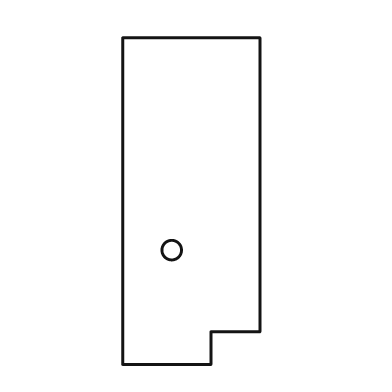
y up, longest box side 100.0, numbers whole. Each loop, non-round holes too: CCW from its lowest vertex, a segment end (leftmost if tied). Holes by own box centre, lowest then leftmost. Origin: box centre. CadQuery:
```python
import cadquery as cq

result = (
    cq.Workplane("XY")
    .moveTo(-21.0, -50.0)
    .lineTo(6.0, -50.0)
    .lineTo(6.0, -40.0)
    .lineTo(21.0, -40.0)
    .lineTo(21.0, 50.0)
    .lineTo(-21.0, 50.0)
    .close()
    .moveTo(-6.0, -15.0)
    .circle(3.0)
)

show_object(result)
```